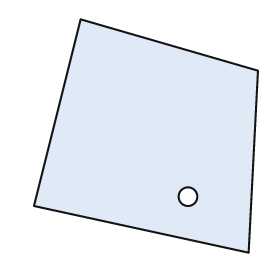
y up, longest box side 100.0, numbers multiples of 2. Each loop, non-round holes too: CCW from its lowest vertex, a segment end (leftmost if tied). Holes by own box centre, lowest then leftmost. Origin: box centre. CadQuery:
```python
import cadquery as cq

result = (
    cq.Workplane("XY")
    .moveTo(44.0, -50.0)
    .lineTo(48.0, 28.0)
    .lineTo(-28.0, 50.0)
    .lineTo(-48.0, -30.0)
    .close()
    .moveTo(18.0, -26.0)
    .circle(4.0)
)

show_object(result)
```